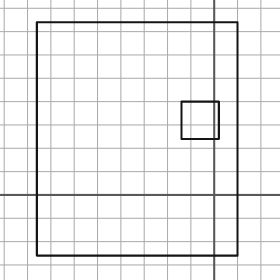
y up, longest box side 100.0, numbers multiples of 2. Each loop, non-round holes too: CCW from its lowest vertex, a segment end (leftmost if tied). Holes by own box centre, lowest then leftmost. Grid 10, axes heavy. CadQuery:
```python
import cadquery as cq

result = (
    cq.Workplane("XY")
    .moveTo(-76.0, -26.0)
    .lineTo(10.0, -26.0)
    .lineTo(10.0, 74.0)
    .lineTo(-76.0, 74.0)
    .close()
    .moveTo(-14.0, 24.0)
    .lineTo(2.0, 24.0)
    .lineTo(2.0, 40.0)
    .lineTo(-14.0, 40.0)
    .close()
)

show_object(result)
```